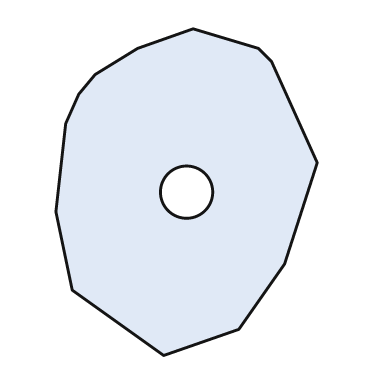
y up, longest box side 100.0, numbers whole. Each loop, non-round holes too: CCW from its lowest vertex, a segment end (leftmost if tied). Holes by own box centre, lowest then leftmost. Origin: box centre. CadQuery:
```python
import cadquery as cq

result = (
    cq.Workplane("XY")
    .moveTo(-7.0, -50.0)
    .lineTo(16.0, -42.0)
    .lineTo(30.0, -22.0)
    .lineTo(40.0, 9.0)
    .lineTo(26.0, 40.0)
    .lineTo(22.0, 44.0)
    .lineTo(2.0, 50.0)
    .lineTo(-15.0, 44.0)
    .lineTo(-28.0, 36.0)
    .lineTo(-33.0, 30.0)
    .lineTo(-37.0, 21.0)
    .lineTo(-40.0, -6.0)
    .lineTo(-35.0, -30.0)
    .close()
    .moveTo(0.0, 0.0)
    .circle(8.0)
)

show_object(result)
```